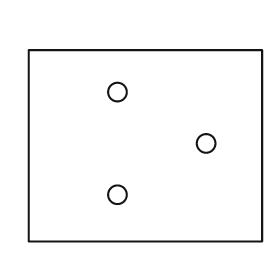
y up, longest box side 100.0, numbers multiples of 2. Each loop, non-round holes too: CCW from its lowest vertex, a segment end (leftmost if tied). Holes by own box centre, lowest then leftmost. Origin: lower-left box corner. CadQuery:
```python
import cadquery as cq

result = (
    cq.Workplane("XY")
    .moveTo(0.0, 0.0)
    .lineTo(100.0, 0.0)
    .lineTo(100.0, 82.0)
    .lineTo(0.0, 82.0)
    .close()
    .moveTo(38.0, 20.0)
    .circle(4.0)
    .moveTo(76.0, 42.0)
    .circle(4.0)
    .moveTo(38.0, 64.0)
    .circle(4.0)
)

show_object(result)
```